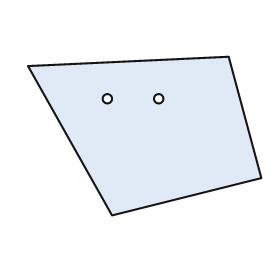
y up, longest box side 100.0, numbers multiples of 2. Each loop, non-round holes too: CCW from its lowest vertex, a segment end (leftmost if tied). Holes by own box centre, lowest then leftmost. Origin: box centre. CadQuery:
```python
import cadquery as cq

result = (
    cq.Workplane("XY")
    .moveTo(-14.0, -34.0)
    .lineTo(50.0, -18.0)
    .lineTo(36.0, 34.0)
    .lineTo(-50.0, 30.0)
    .close()
    .moveTo(-16.0, 16.0)
    .circle(2.0)
    .moveTo(6.0, 16.0)
    .circle(2.0)
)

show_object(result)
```